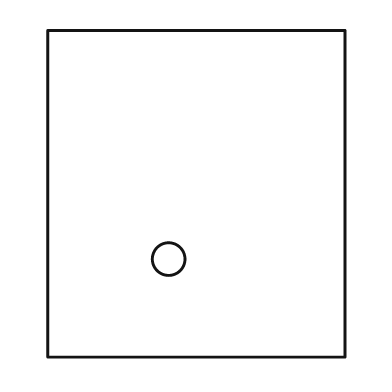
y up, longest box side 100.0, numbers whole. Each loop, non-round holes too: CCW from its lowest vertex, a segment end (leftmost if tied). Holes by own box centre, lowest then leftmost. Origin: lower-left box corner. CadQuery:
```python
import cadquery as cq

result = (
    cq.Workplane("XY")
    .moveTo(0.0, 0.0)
    .lineTo(91.0, 0.0)
    .lineTo(91.0, 100.0)
    .lineTo(0.0, 100.0)
    .close()
    .moveTo(37.0, 30.0)
    .circle(5.0)
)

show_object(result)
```